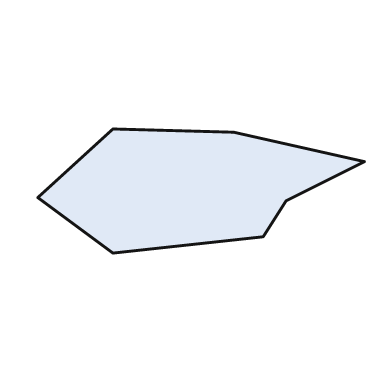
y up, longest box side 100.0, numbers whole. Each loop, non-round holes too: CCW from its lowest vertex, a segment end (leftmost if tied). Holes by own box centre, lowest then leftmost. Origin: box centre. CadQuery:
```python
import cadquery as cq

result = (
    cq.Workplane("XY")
    .moveTo(-27.0, -19.0)
    .lineTo(19.0, -14.0)
    .lineTo(26.0, -3.0)
    .lineTo(50.0, 9.0)
    .lineTo(10.0, 18.0)
    .lineTo(-27.0, 19.0)
    .lineTo(-50.0, -2.0)
    .close()
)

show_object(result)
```